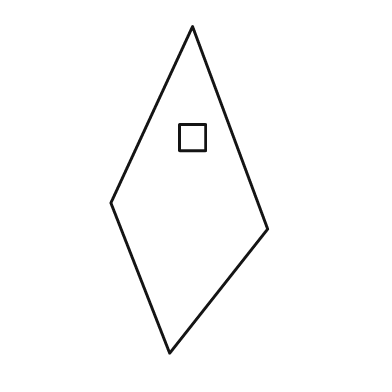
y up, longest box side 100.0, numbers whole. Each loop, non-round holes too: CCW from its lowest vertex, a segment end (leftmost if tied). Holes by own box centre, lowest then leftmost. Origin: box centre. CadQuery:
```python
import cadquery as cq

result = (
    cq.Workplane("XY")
    .moveTo(-6.0, -50.0)
    .lineTo(24.0, -12.0)
    .lineTo(1.0, 50.0)
    .lineTo(-24.0, -4.0)
    .close()
    .moveTo(-3.0, 12.0)
    .lineTo(5.0, 12.0)
    .lineTo(5.0, 20.0)
    .lineTo(-3.0, 20.0)
    .close()
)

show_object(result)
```